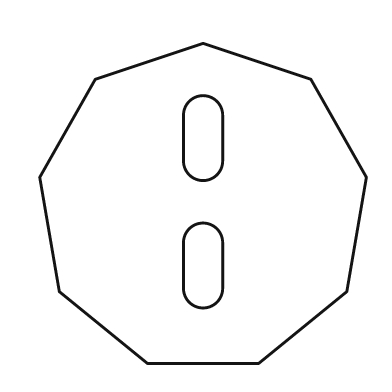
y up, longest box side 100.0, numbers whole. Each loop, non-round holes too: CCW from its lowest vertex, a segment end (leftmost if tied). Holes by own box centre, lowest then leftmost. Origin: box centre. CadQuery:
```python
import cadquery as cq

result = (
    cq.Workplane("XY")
    .moveTo(-17.0, -49.0)
    .lineTo(17.0, -49.0)
    .lineTo(44.0, -27.0)
    .lineTo(50.0, 8.0)
    .lineTo(33.0, 38.0)
    .lineTo(0.0, 49.0)
    .lineTo(-33.0, 38.0)
    .lineTo(-50.0, 8.0)
    .lineTo(-44.0, -27.0)
    .close()
    .moveTo(-6.0, -26.0)
    .threePointArc((0.0, -32.0), (6.0, -26.0))
    .lineTo(6.0, -12.0)
    .threePointArc((0.0, -6.0), (-6.0, -12.0))
    .close()
    .moveTo(-6.0, 13.0)
    .threePointArc((0.0, 7.0), (6.0, 13.0))
    .lineTo(6.0, 27.0)
    .threePointArc((0.0, 33.0), (-6.0, 27.0))
    .close()
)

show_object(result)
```